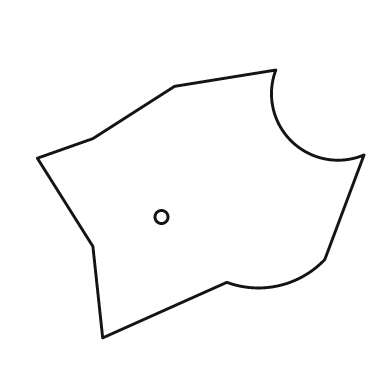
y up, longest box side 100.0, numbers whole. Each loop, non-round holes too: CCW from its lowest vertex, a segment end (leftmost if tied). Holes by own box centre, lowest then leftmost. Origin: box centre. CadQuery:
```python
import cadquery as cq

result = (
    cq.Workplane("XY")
    .moveTo(-30.0, -41.0)
    .lineTo(8.0, -24.0)
    .threePointArc((24.0, -25.0), (38.0, -17.0))
    .lineTo(50.0, 15.0)
    .threePointArc((28.0, 19.0), (23.0, 41.0))
    .lineTo(-8.0, 36.0)
    .lineTo(-33.0, 20.0)
    .lineTo(-50.0, 14.0)
    .lineTo(-33.0, -13.0)
    .close()
    .moveTo(-12.0, -4.0)
    .circle(2.0)
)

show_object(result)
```